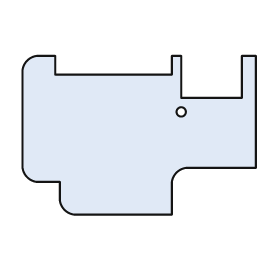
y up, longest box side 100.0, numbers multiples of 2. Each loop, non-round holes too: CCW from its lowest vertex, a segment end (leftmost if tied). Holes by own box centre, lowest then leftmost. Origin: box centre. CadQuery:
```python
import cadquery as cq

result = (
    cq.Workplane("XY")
    .moveTo(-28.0, -34.0)
    .lineTo(14.0, -34.0)
    .lineTo(14.0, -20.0)
    .threePointArc((16.0, -16.0), (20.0, -14.0))
    .lineTo(50.0, -14.0)
    .lineTo(50.0, 34.0)
    .lineTo(44.0, 34.0)
    .lineTo(44.0, 16.0)
    .lineTo(18.0, 16.0)
    .lineTo(18.0, 34.0)
    .lineTo(14.0, 34.0)
    .lineTo(14.0, 26.0)
    .lineTo(-36.0, 26.0)
    .lineTo(-36.0, 34.0)
    .lineTo(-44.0, 34.0)
    .threePointArc((-48.0, 32.0), (-50.0, 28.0))
    .lineTo(-50.0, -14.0)
    .threePointArc((-48.0, -18.0), (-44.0, -20.0))
    .lineTo(-34.0, -20.0)
    .lineTo(-34.0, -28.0)
    .threePointArc((-32.0, -32.0), (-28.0, -34.0))
    .close()
    .moveTo(18.0, 10.0)
    .circle(2.0)
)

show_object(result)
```